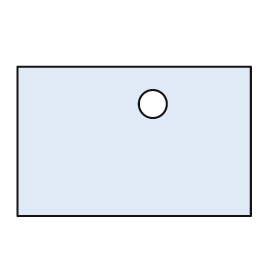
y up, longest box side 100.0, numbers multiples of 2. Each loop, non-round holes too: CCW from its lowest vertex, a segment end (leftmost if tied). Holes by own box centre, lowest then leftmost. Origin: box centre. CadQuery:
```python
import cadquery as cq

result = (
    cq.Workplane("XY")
    .moveTo(-50.0, -32.0)
    .lineTo(50.0, -32.0)
    .lineTo(50.0, 32.0)
    .lineTo(-50.0, 32.0)
    .close()
    .moveTo(8.0, 16.0)
    .circle(6.0)
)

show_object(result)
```